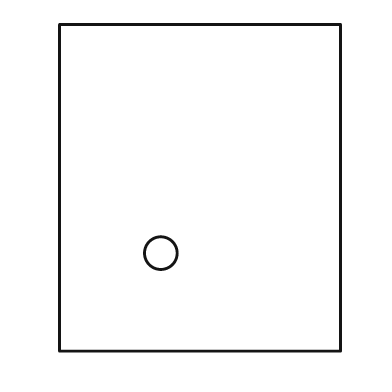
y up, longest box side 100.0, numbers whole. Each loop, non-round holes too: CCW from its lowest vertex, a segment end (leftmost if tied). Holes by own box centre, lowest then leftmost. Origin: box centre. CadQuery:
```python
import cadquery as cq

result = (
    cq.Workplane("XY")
    .moveTo(-43.0, -50.0)
    .lineTo(43.0, -50.0)
    .lineTo(43.0, 50.0)
    .lineTo(-43.0, 50.0)
    .close()
    .moveTo(-12.0, -20.0)
    .circle(5.0)
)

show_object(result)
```